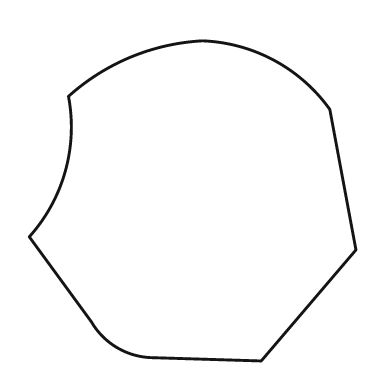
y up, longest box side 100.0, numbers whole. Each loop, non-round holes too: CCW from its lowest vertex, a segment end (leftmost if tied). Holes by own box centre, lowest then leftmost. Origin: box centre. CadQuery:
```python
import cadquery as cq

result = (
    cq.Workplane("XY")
    .moveTo(21.0, -49.0)
    .lineTo(50.0, -15.0)
    .lineTo(42.0, 28.0)
    .threePointArc((25.0, 43.0), (3.0, 49.0))
    .threePointArc((-19.0, 44.0), (-38.0, 32.0))
    .threePointArc((-39.0, 9.0), (-50.0, -11.0))
    .lineTo(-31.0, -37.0)
    .threePointArc((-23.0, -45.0), (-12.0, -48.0))
    .close()
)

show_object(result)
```